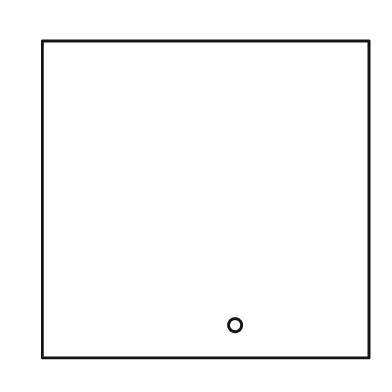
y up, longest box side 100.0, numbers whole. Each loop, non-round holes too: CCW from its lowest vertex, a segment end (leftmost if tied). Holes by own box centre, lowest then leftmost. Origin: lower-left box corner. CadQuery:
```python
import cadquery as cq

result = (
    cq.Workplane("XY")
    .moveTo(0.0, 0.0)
    .lineTo(100.0, 0.0)
    .lineTo(100.0, 97.0)
    .lineTo(0.0, 97.0)
    .close()
    .moveTo(59.0, 10.0)
    .circle(2.0)
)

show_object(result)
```